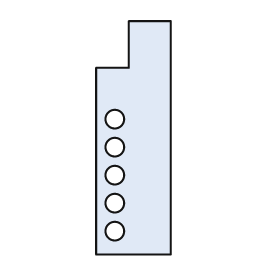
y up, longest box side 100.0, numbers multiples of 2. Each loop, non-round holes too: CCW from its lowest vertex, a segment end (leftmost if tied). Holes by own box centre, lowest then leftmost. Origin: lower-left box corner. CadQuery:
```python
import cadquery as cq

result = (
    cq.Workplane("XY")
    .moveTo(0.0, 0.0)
    .lineTo(32.0, 0.0)
    .lineTo(32.0, 100.0)
    .lineTo(14.0, 100.0)
    .lineTo(14.0, 80.0)
    .lineTo(0.0, 80.0)
    .close()
    .moveTo(8.0, 10.0)
    .circle(4.0)
    .moveTo(8.0, 22.0)
    .circle(4.0)
    .moveTo(8.0, 34.0)
    .circle(4.0)
    .moveTo(8.0, 46.0)
    .circle(4.0)
    .moveTo(8.0, 58.0)
    .circle(4.0)
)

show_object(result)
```